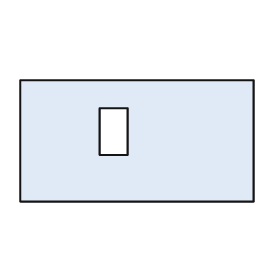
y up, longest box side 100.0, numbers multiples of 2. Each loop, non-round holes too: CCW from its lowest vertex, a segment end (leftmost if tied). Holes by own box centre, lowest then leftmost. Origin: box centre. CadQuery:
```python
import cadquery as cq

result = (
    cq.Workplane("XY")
    .moveTo(-50.0, -26.0)
    .lineTo(50.0, -26.0)
    .lineTo(50.0, 26.0)
    .lineTo(-50.0, 26.0)
    .close()
    .moveTo(-16.0, -6.0)
    .lineTo(-4.0, -6.0)
    .lineTo(-4.0, 14.0)
    .lineTo(-16.0, 14.0)
    .close()
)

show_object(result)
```